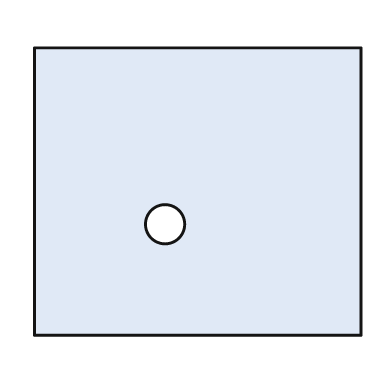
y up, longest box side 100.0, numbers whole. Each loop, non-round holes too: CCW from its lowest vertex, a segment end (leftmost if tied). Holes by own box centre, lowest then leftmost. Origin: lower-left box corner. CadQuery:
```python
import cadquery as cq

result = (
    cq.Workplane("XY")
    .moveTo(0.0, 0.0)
    .lineTo(100.0, 0.0)
    .lineTo(100.0, 88.0)
    .lineTo(0.0, 88.0)
    .close()
    .moveTo(40.0, 34.0)
    .circle(6.0)
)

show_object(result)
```